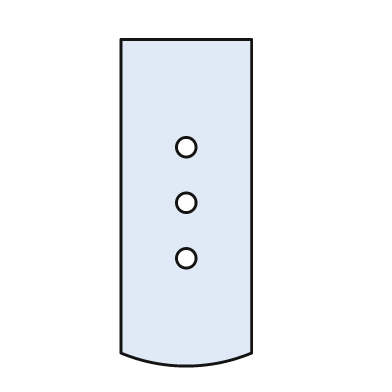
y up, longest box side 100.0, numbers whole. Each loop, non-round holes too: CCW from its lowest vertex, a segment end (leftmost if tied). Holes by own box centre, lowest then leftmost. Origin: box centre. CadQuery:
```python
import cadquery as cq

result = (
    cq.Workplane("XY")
    .moveTo(-20.0, -46.0)
    .threePointArc((0.0, -50.0), (20.0, -46.0))
    .lineTo(20.0, 50.0)
    .lineTo(-20.0, 50.0)
    .close()
    .moveTo(0.0, -17.0)
    .circle(3.0)
    .moveTo(0.0, 0.0)
    .circle(3.0)
    .moveTo(0.0, 17.0)
    .circle(3.0)
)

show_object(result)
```